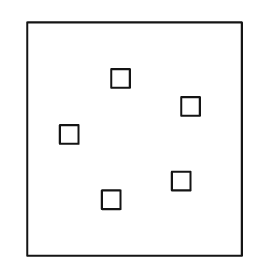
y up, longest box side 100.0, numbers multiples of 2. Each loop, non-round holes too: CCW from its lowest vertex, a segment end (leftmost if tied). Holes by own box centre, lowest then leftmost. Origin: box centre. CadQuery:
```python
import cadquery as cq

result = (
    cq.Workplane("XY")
    .moveTo(-46.0, -50.0)
    .lineTo(46.0, -50.0)
    .lineTo(46.0, 50.0)
    .lineTo(-46.0, 50.0)
    .close()
    .moveTo(-14.0, -30.0)
    .lineTo(-6.0, -30.0)
    .lineTo(-6.0, -22.0)
    .lineTo(-14.0, -22.0)
    .close()
    .moveTo(16.0, -22.0)
    .lineTo(24.0, -22.0)
    .lineTo(24.0, -14.0)
    .lineTo(16.0, -14.0)
    .close()
    .moveTo(-32.0, -2.0)
    .lineTo(-24.0, -2.0)
    .lineTo(-24.0, 6.0)
    .lineTo(-32.0, 6.0)
    .close()
    .moveTo(20.0, 10.0)
    .lineTo(28.0, 10.0)
    .lineTo(28.0, 18.0)
    .lineTo(20.0, 18.0)
    .close()
    .moveTo(-10.0, 22.0)
    .lineTo(-2.0, 22.0)
    .lineTo(-2.0, 30.0)
    .lineTo(-10.0, 30.0)
    .close()
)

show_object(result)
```